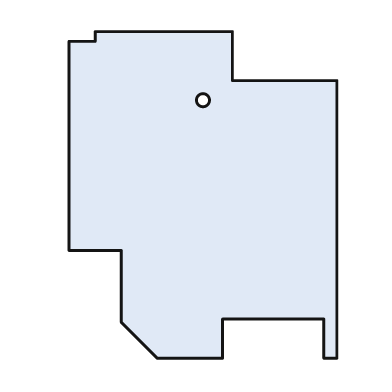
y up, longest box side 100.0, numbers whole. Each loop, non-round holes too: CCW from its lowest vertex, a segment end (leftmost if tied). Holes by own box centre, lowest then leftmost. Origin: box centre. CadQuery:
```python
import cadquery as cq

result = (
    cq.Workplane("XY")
    .moveTo(-14.0, -50.0)
    .lineTo(6.0, -50.0)
    .lineTo(6.0, -38.0)
    .lineTo(37.0, -38.0)
    .lineTo(37.0, -50.0)
    .lineTo(41.0, -50.0)
    .lineTo(41.0, 35.0)
    .lineTo(9.0, 35.0)
    .lineTo(9.0, 50.0)
    .lineTo(-33.0, 50.0)
    .lineTo(-33.0, 47.0)
    .lineTo(-41.0, 47.0)
    .lineTo(-41.0, -17.0)
    .lineTo(-25.0, -17.0)
    .lineTo(-25.0, -39.0)
    .close()
    .moveTo(0.0, 29.0)
    .circle(2.0)
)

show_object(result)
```